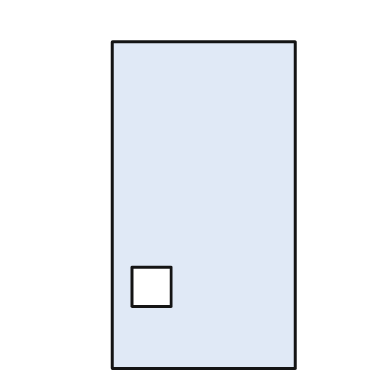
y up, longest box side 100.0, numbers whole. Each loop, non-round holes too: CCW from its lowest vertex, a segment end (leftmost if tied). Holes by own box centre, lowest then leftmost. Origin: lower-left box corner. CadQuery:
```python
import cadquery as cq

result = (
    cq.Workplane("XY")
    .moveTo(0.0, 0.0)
    .lineTo(56.0, 0.0)
    .lineTo(56.0, 100.0)
    .lineTo(0.0, 100.0)
    .close()
    .moveTo(6.0, 19.0)
    .lineTo(18.0, 19.0)
    .lineTo(18.0, 31.0)
    .lineTo(6.0, 31.0)
    .close()
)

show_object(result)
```